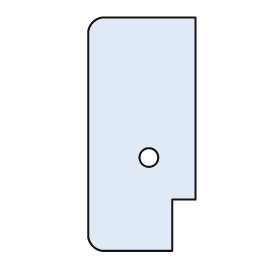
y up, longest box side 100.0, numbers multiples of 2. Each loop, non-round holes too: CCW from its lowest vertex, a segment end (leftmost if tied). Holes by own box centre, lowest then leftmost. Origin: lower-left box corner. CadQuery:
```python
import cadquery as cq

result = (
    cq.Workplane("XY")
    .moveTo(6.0, 0.0)
    .lineTo(36.0, 0.0)
    .lineTo(36.0, 22.0)
    .lineTo(46.0, 22.0)
    .lineTo(46.0, 100.0)
    .lineTo(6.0, 100.0)
    .threePointArc((2.0, 98.0), (0.0, 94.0))
    .lineTo(0.0, 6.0)
    .threePointArc((2.0, 2.0), (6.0, 0.0))
    .close()
    .moveTo(26.0, 40.0)
    .circle(4.0)
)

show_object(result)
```